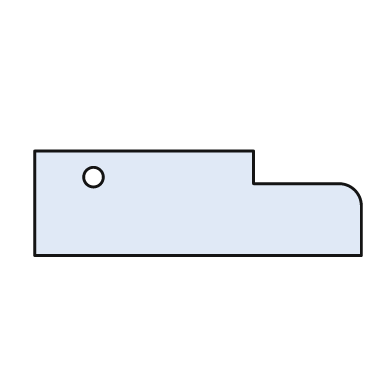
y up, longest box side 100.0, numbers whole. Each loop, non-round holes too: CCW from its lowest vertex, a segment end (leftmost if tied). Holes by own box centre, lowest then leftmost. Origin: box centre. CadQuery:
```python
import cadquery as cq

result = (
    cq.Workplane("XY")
    .moveTo(-50.0, -16.0)
    .lineTo(50.0, -16.0)
    .lineTo(50.0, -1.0)
    .threePointArc((48.0, 4.0), (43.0, 6.0))
    .lineTo(17.0, 6.0)
    .lineTo(17.0, 16.0)
    .lineTo(-50.0, 16.0)
    .close()
    .moveTo(-32.0, 8.0)
    .circle(3.0)
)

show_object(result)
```